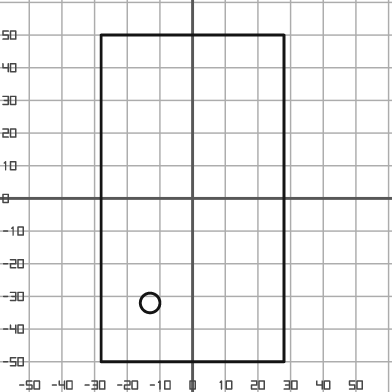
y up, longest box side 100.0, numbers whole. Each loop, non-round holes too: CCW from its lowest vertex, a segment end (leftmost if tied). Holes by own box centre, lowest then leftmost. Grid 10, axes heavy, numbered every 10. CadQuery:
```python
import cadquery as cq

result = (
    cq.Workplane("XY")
    .moveTo(-28.0, -50.0)
    .lineTo(28.0, -50.0)
    .lineTo(28.0, 50.0)
    .lineTo(-28.0, 50.0)
    .close()
    .moveTo(-13.0, -32.0)
    .circle(3.0)
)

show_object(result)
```